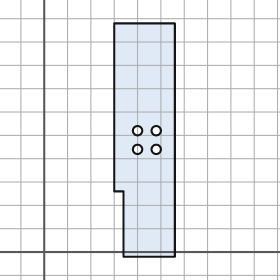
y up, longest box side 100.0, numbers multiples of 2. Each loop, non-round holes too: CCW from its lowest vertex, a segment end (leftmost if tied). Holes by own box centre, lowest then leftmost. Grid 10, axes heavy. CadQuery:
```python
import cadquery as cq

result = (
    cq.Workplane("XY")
    .moveTo(34.0, -2.0)
    .lineTo(56.0, -2.0)
    .lineTo(56.0, 98.0)
    .lineTo(30.0, 98.0)
    .lineTo(30.0, 26.0)
    .lineTo(34.0, 26.0)
    .close()
    .moveTo(40.0, 44.0)
    .circle(2.0)
    .moveTo(48.0, 44.0)
    .circle(2.0)
    .moveTo(40.0, 52.0)
    .circle(2.0)
    .moveTo(48.0, 52.0)
    .circle(2.0)
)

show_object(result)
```